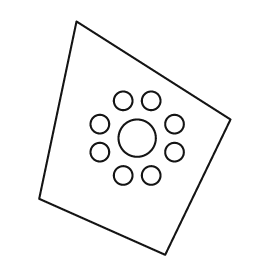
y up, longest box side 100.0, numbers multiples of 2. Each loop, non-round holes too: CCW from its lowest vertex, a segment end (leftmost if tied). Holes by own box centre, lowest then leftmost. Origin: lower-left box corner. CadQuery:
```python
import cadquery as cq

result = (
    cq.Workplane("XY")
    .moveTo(54.0, 0.0)
    .lineTo(82.0, 58.0)
    .lineTo(16.0, 100.0)
    .lineTo(0.0, 24.0)
    .close()
    .moveTo(36.0, 34.0)
    .circle(4.0)
    .moveTo(48.0, 34.0)
    .circle(4.0)
    .moveTo(26.0, 44.0)
    .circle(4.0)
    .moveTo(58.0, 44.0)
    .circle(4.0)
    .moveTo(42.0, 50.0)
    .circle(8.0)
    .moveTo(26.0, 56.0)
    .circle(4.0)
    .moveTo(58.0, 56.0)
    .circle(4.0)
    .moveTo(36.0, 66.0)
    .circle(4.0)
    .moveTo(48.0, 66.0)
    .circle(4.0)
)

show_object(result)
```